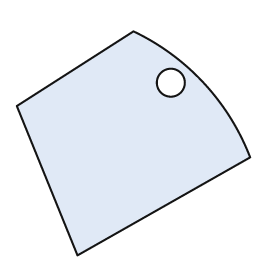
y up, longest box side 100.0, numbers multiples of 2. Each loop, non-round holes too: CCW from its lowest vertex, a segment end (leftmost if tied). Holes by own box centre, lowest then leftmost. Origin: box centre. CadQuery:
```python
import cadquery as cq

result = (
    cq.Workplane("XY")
    .moveTo(-24.0, -48.0)
    .lineTo(50.0, -6.0)
    .threePointArc((30.0, 26.0), (0.0, 48.0))
    .lineTo(-50.0, 16.0)
    .close()
    .moveTo(16.0, 26.0)
    .circle(6.0)
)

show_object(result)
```